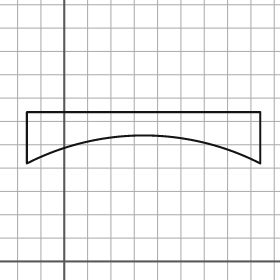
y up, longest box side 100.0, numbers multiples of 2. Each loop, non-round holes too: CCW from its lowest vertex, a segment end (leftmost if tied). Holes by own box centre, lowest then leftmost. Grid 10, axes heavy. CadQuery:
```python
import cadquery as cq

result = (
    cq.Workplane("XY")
    .moveTo(-16.0, 42.0)
    .threePointArc((34.0, 54.0), (84.0, 42.0))
    .lineTo(84.0, 64.0)
    .lineTo(-16.0, 64.0)
    .close()
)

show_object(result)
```